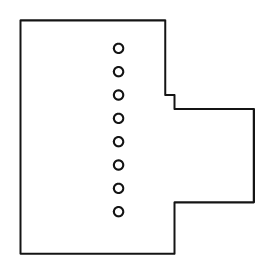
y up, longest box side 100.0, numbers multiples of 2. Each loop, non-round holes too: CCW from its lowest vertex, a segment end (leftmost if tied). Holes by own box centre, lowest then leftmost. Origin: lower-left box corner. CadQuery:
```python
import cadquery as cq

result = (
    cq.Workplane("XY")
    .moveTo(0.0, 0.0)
    .lineTo(66.0, 0.0)
    .lineTo(66.0, 22.0)
    .lineTo(100.0, 22.0)
    .lineTo(100.0, 62.0)
    .lineTo(66.0, 62.0)
    .lineTo(66.0, 68.0)
    .lineTo(62.0, 68.0)
    .lineTo(62.0, 100.0)
    .lineTo(0.0, 100.0)
    .close()
    .moveTo(42.0, 18.0)
    .circle(2.0)
    .moveTo(42.0, 28.0)
    .circle(2.0)
    .moveTo(42.0, 38.0)
    .circle(2.0)
    .moveTo(42.0, 48.0)
    .circle(2.0)
    .moveTo(42.0, 58.0)
    .circle(2.0)
    .moveTo(42.0, 68.0)
    .circle(2.0)
    .moveTo(42.0, 78.0)
    .circle(2.0)
    .moveTo(42.0, 88.0)
    .circle(2.0)
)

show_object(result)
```